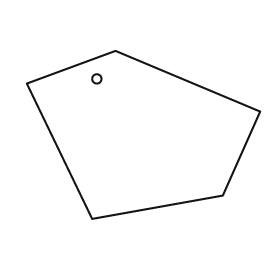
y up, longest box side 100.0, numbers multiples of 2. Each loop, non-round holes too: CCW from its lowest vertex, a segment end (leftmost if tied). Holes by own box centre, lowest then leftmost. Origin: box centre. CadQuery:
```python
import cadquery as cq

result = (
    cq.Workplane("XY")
    .moveTo(-22.0, -36.0)
    .lineTo(34.0, -26.0)
    .lineTo(50.0, 10.0)
    .lineTo(-12.0, 36.0)
    .lineTo(-50.0, 22.0)
    .close()
    .moveTo(-20.0, 24.0)
    .circle(2.0)
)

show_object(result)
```